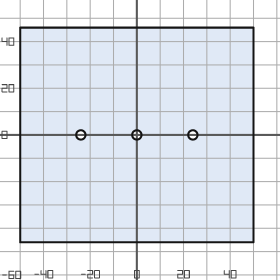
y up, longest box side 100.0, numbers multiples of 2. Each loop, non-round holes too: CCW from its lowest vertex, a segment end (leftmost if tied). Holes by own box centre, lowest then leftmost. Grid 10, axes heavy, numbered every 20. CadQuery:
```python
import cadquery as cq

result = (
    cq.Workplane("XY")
    .moveTo(-50.0, -46.0)
    .lineTo(50.0, -46.0)
    .lineTo(50.0, 46.0)
    .lineTo(-50.0, 46.0)
    .close()
    .moveTo(-24.0, 0.0)
    .circle(2.0)
    .moveTo(0.0, 0.0)
    .circle(2.0)
    .moveTo(24.0, 0.0)
    .circle(2.0)
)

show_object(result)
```